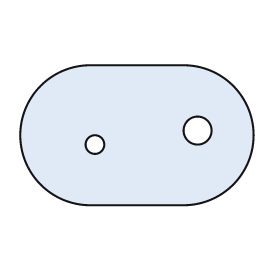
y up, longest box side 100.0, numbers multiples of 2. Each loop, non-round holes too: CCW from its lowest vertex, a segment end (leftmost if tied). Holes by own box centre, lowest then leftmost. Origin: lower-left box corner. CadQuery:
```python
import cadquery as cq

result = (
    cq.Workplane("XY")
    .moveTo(30.0, 0.0)
    .lineTo(70.0, 0.0)
    .threePointArc((100.0, 30.0), (70.0, 60.0))
    .lineTo(30.0, 60.0)
    .threePointArc((0.0, 30.0), (30.0, 0.0))
    .close()
    .moveTo(32.0, 26.0)
    .circle(4.0)
    .moveTo(76.0, 32.0)
    .circle(6.0)
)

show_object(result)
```